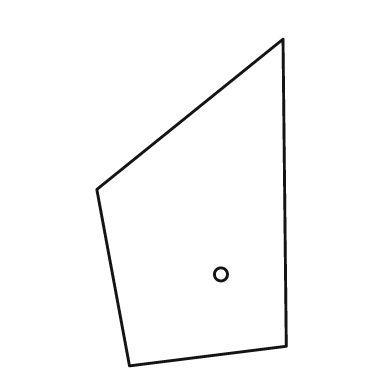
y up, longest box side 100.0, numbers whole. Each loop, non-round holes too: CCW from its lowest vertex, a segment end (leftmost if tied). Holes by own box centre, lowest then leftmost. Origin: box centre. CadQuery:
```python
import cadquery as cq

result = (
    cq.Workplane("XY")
    .moveTo(-19.0, -50.0)
    .lineTo(29.0, -44.0)
    .lineTo(28.0, 50.0)
    .lineTo(-29.0, 4.0)
    .close()
    .moveTo(9.0, -22.0)
    .circle(2.0)
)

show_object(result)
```